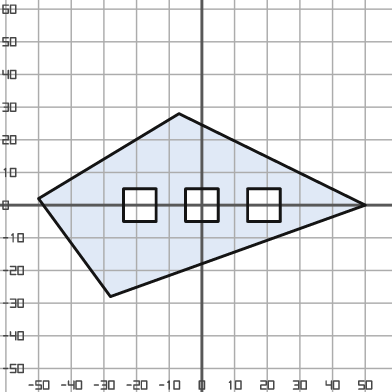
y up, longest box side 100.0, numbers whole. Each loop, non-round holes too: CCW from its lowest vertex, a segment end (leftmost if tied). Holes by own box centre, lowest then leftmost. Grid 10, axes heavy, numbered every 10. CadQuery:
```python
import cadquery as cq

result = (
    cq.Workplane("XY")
    .moveTo(-28.0, -28.0)
    .lineTo(50.0, 0.0)
    .lineTo(-7.0, 28.0)
    .lineTo(-50.0, 2.0)
    .close()
    .moveTo(-24.0, -5.0)
    .lineTo(-14.0, -5.0)
    .lineTo(-14.0, 5.0)
    .lineTo(-24.0, 5.0)
    .close()
    .moveTo(-5.0, -5.0)
    .lineTo(5.0, -5.0)
    .lineTo(5.0, 5.0)
    .lineTo(-5.0, 5.0)
    .close()
    .moveTo(14.0, -5.0)
    .lineTo(24.0, -5.0)
    .lineTo(24.0, 5.0)
    .lineTo(14.0, 5.0)
    .close()
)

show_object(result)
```